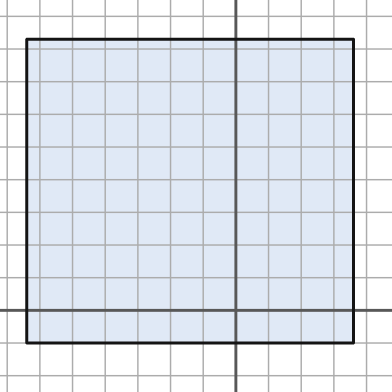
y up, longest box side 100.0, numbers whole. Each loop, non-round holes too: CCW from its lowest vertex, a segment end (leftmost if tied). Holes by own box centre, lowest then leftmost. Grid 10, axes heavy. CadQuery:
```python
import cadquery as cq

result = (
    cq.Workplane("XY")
    .moveTo(-64.0, -10.0)
    .lineTo(36.0, -10.0)
    .lineTo(36.0, 83.0)
    .lineTo(-64.0, 83.0)
    .close()
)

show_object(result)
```